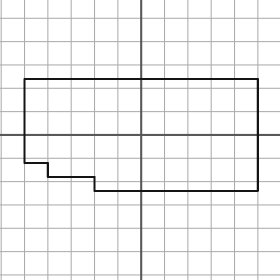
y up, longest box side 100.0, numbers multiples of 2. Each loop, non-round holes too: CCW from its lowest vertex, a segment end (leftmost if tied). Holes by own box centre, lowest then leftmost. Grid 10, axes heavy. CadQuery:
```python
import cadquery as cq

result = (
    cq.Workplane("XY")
    .moveTo(-20.0, -24.0)
    .lineTo(50.0, -24.0)
    .lineTo(50.0, 24.0)
    .lineTo(-50.0, 24.0)
    .lineTo(-50.0, -12.0)
    .lineTo(-40.0, -12.0)
    .lineTo(-40.0, -18.0)
    .lineTo(-20.0, -18.0)
    .close()
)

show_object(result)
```